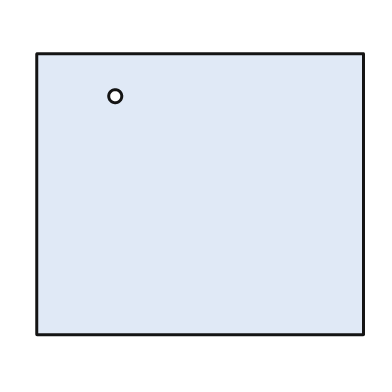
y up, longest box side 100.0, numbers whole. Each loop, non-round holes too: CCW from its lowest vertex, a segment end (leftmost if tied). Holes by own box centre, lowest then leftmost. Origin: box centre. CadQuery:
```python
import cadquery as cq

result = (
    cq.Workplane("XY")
    .moveTo(-50.0, -43.0)
    .lineTo(50.0, -43.0)
    .lineTo(50.0, 43.0)
    .lineTo(-50.0, 43.0)
    .close()
    .moveTo(-26.0, 30.0)
    .circle(2.0)
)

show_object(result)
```